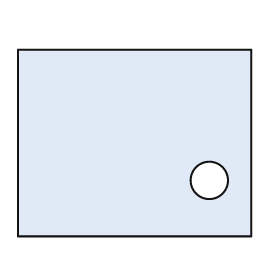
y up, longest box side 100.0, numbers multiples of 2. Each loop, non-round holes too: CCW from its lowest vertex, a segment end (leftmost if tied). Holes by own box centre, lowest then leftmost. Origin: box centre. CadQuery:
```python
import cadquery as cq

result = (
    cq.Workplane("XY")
    .moveTo(-50.0, -40.0)
    .lineTo(50.0, -40.0)
    .lineTo(50.0, 40.0)
    .lineTo(-50.0, 40.0)
    .close()
    .moveTo(32.0, -16.0)
    .circle(8.0)
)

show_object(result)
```